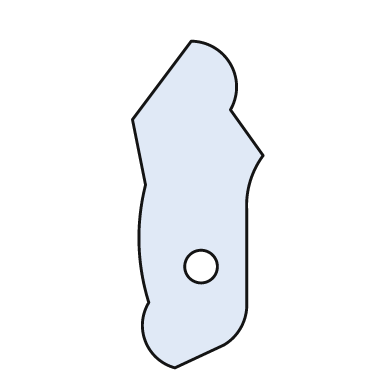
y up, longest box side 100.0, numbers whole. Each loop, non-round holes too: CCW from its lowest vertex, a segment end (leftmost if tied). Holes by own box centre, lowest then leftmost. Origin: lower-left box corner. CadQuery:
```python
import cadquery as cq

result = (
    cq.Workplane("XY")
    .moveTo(13.0, 0.0)
    .lineTo(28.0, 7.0)
    .threePointArc((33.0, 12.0), (35.0, 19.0))
    .lineTo(35.0, 48.0)
    .threePointArc((36.0, 57.0), (40.0, 65.0))
    .lineTo(30.0, 79.0)
    .threePointArc((30.0, 93.0), (18.0, 100.0))
    .lineTo(0.0, 76.0)
    .lineTo(4.0, 56.0)
    .threePointArc((2.0, 38.0), (5.0, 20.0))
    .threePointArc((4.0, 8.0), (13.0, 0.0))
    .close()
    .moveTo(21.0, 31.0)
    .circle(5.0)
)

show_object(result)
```